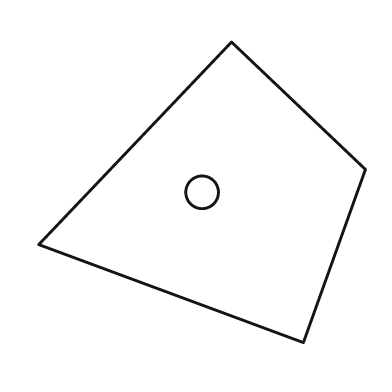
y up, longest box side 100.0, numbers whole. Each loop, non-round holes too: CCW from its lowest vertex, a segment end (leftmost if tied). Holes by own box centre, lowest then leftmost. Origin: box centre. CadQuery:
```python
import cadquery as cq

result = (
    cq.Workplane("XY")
    .moveTo(31.0, -46.0)
    .lineTo(50.0, 7.0)
    .lineTo(9.0, 46.0)
    .lineTo(-50.0, -16.0)
    .close()
    .moveTo(0.0, 0.0)
    .circle(5.0)
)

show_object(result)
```